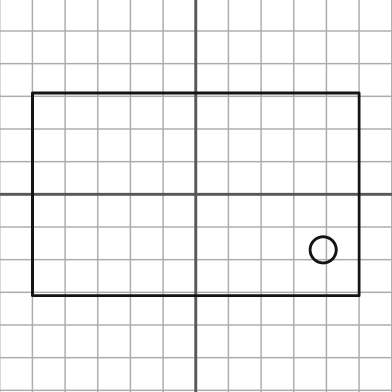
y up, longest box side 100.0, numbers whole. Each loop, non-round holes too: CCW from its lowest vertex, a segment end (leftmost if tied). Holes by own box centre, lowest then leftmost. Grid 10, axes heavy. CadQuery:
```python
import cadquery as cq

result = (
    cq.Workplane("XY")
    .moveTo(-50.0, -31.0)
    .lineTo(50.0, -31.0)
    .lineTo(50.0, 31.0)
    .lineTo(-50.0, 31.0)
    .close()
    .moveTo(39.0, -17.0)
    .circle(4.0)
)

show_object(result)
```